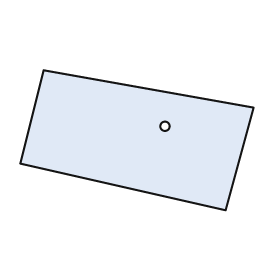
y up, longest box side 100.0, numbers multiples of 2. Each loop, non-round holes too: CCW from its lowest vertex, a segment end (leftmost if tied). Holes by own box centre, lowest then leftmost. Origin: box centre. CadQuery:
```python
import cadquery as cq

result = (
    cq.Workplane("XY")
    .moveTo(38.0, -30.0)
    .lineTo(50.0, 14.0)
    .lineTo(-40.0, 30.0)
    .lineTo(-50.0, -10.0)
    .close()
    .moveTo(12.0, 6.0)
    .circle(2.0)
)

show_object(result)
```